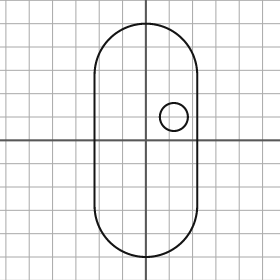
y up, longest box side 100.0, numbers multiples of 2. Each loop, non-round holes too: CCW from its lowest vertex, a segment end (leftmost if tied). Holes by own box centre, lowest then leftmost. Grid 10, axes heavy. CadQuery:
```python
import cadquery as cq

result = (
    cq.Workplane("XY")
    .moveTo(-22.0, -28.0)
    .threePointArc((0.0, -50.0), (22.0, -28.0))
    .lineTo(22.0, 28.0)
    .threePointArc((0.0, 50.0), (-22.0, 28.0))
    .close()
    .moveTo(12.0, 10.0)
    .circle(6.0)
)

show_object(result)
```